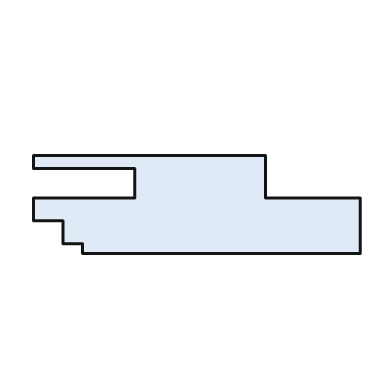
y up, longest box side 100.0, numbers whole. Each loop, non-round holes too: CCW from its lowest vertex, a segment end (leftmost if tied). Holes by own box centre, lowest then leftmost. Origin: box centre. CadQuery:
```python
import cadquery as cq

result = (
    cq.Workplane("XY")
    .moveTo(-35.0, -15.0)
    .lineTo(50.0, -15.0)
    .lineTo(50.0, 2.0)
    .lineTo(21.0, 2.0)
    .lineTo(21.0, 15.0)
    .lineTo(-50.0, 15.0)
    .lineTo(-50.0, 11.0)
    .lineTo(-19.0, 11.0)
    .lineTo(-19.0, 2.0)
    .lineTo(-50.0, 2.0)
    .lineTo(-50.0, -5.0)
    .lineTo(-41.0, -5.0)
    .lineTo(-41.0, -12.0)
    .lineTo(-35.0, -12.0)
    .close()
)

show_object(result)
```